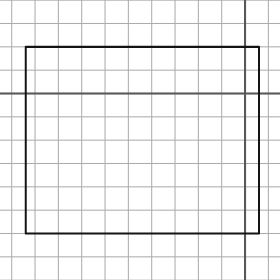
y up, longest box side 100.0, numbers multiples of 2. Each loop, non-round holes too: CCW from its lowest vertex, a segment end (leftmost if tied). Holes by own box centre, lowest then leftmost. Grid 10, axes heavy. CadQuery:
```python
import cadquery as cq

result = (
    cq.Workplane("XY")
    .moveTo(-94.0, -60.0)
    .lineTo(6.0, -60.0)
    .lineTo(6.0, 20.0)
    .lineTo(-94.0, 20.0)
    .close()
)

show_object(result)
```